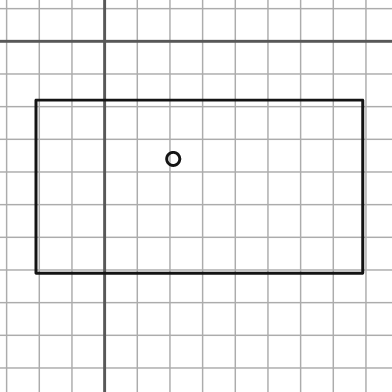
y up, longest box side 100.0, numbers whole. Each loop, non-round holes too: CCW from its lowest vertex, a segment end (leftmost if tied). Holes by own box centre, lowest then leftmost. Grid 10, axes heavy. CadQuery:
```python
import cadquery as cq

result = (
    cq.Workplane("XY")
    .moveTo(-21.0, -71.0)
    .lineTo(79.0, -71.0)
    .lineTo(79.0, -18.0)
    .lineTo(-21.0, -18.0)
    .close()
    .moveTo(21.0, -36.0)
    .circle(2.0)
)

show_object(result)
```